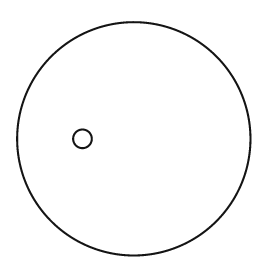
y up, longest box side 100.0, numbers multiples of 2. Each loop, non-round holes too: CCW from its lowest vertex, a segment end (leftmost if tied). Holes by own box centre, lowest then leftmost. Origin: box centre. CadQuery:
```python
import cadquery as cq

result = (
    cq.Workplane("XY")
    .moveTo(0.0, 0.0)
    .circle(50.0)
    .moveTo(-22.0, 0.0)
    .circle(4.0)
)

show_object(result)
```